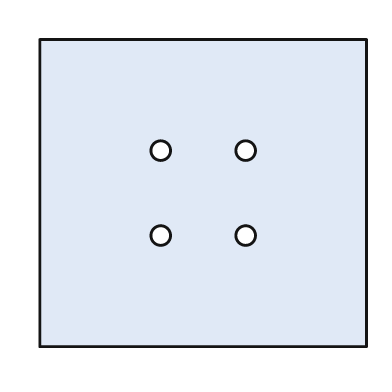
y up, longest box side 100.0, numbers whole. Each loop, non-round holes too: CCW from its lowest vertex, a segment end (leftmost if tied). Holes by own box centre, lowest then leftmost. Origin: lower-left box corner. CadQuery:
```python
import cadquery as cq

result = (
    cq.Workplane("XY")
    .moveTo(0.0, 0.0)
    .lineTo(100.0, 0.0)
    .lineTo(100.0, 94.0)
    .lineTo(0.0, 94.0)
    .close()
    .moveTo(37.0, 34.0)
    .circle(3.0)
    .moveTo(63.0, 34.0)
    .circle(3.0)
    .moveTo(37.0, 60.0)
    .circle(3.0)
    .moveTo(63.0, 60.0)
    .circle(3.0)
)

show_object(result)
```